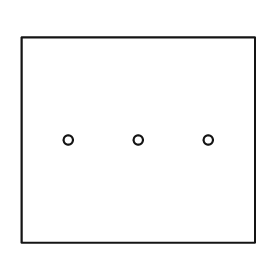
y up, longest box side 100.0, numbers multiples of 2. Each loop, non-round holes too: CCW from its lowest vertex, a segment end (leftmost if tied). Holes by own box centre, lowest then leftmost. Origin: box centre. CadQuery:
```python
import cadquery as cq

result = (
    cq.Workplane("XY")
    .moveTo(-50.0, -44.0)
    .lineTo(50.0, -44.0)
    .lineTo(50.0, 44.0)
    .lineTo(-50.0, 44.0)
    .close()
    .moveTo(-30.0, 0.0)
    .circle(2.0)
    .moveTo(0.0, 0.0)
    .circle(2.0)
    .moveTo(30.0, 0.0)
    .circle(2.0)
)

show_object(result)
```